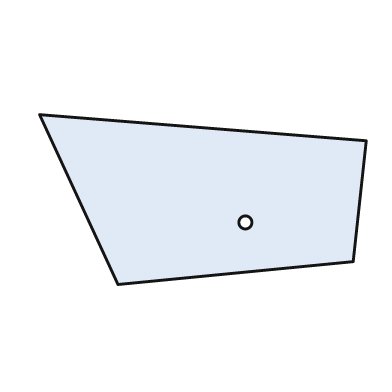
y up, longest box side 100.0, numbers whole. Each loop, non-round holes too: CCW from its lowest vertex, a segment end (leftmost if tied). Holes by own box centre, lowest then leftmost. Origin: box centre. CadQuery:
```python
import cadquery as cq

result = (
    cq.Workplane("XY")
    .moveTo(-26.0, -26.0)
    .lineTo(46.0, -19.0)
    .lineTo(50.0, 18.0)
    .lineTo(-50.0, 26.0)
    .close()
    .moveTo(13.0, -7.0)
    .circle(2.0)
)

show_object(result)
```